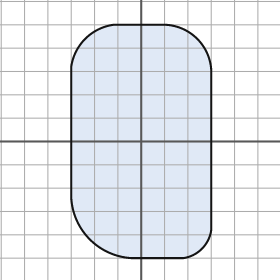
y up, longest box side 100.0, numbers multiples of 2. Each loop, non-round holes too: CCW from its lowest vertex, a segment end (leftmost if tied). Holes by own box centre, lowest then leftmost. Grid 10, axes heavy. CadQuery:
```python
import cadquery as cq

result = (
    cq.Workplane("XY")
    .moveTo(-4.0, -50.0)
    .lineTo(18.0, -50.0)
    .threePointArc((26.0, -46.0), (30.0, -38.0))
    .lineTo(30.0, 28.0)
    .threePointArc((24.0, 44.0), (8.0, 50.0))
    .lineTo(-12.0, 50.0)
    .threePointArc((-24.0, 44.0), (-30.0, 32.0))
    .lineTo(-30.0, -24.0)
    .threePointArc((-22.0, -42.0), (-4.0, -50.0))
    .close()
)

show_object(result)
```